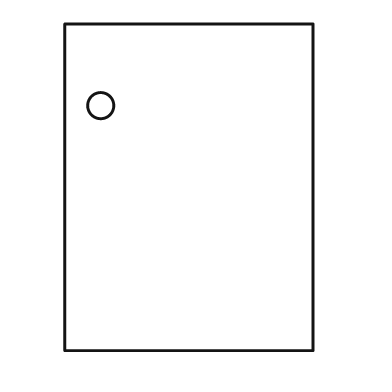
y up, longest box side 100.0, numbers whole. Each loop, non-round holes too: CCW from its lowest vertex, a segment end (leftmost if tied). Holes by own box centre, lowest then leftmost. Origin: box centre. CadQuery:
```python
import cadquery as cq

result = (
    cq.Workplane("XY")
    .moveTo(-38.0, -50.0)
    .lineTo(38.0, -50.0)
    .lineTo(38.0, 50.0)
    .lineTo(-38.0, 50.0)
    .close()
    .moveTo(-27.0, 25.0)
    .circle(4.0)
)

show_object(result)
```